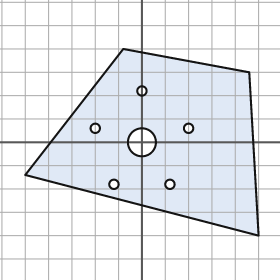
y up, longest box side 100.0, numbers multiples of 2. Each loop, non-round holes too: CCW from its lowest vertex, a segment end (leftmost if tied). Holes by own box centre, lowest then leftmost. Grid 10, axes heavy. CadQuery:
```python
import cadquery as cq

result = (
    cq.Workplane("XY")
    .moveTo(50.0, -40.0)
    .lineTo(46.0, 30.0)
    .lineTo(-8.0, 40.0)
    .lineTo(-50.0, -14.0)
    .close()
    .moveTo(-12.0, -18.0)
    .circle(2.0)
    .moveTo(12.0, -18.0)
    .circle(2.0)
    .moveTo(0.0, 0.0)
    .circle(6.0)
    .moveTo(-20.0, 6.0)
    .circle(2.0)
    .moveTo(20.0, 6.0)
    .circle(2.0)
    .moveTo(0.0, 22.0)
    .circle(2.0)
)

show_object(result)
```